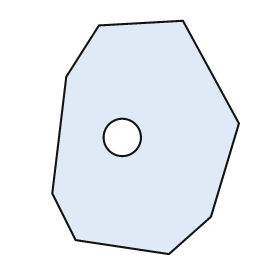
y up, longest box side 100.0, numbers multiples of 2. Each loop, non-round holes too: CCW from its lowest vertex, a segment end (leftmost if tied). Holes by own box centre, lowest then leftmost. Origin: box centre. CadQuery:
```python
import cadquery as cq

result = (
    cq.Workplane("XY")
    .moveTo(10.0, -50.0)
    .lineTo(28.0, -34.0)
    .lineTo(40.0, 6.0)
    .lineTo(16.0, 50.0)
    .lineTo(-20.0, 48.0)
    .lineTo(-34.0, 26.0)
    .lineTo(-40.0, -24.0)
    .lineTo(-30.0, -44.0)
    .close()
    .moveTo(-10.0, 0.0)
    .circle(8.0)
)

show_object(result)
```